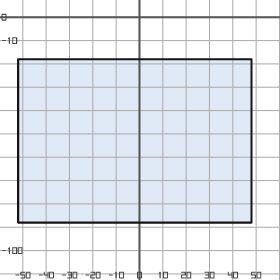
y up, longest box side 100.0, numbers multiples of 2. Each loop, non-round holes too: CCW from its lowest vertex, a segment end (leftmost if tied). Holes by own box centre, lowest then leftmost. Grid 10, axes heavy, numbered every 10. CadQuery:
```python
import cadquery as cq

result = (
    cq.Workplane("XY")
    .moveTo(-52.0, -88.0)
    .lineTo(48.0, -88.0)
    .lineTo(48.0, -18.0)
    .lineTo(-52.0, -18.0)
    .close()
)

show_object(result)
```